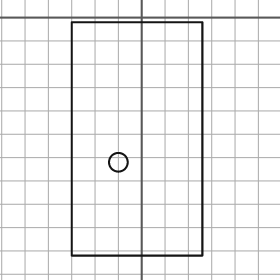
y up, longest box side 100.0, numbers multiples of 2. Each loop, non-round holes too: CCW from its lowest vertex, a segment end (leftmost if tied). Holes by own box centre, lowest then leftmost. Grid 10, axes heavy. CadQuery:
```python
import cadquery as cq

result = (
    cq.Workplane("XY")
    .moveTo(-30.0, -102.0)
    .lineTo(26.0, -102.0)
    .lineTo(26.0, -2.0)
    .lineTo(-30.0, -2.0)
    .close()
    .moveTo(-10.0, -62.0)
    .circle(4.0)
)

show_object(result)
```